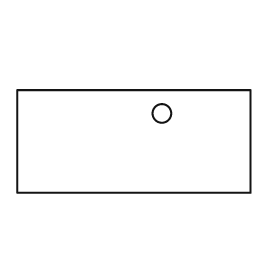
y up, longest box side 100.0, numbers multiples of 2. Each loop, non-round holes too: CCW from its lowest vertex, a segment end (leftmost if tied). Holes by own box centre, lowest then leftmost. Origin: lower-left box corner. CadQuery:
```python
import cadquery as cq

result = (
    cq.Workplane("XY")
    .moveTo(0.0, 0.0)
    .lineTo(100.0, 0.0)
    .lineTo(100.0, 44.0)
    .lineTo(0.0, 44.0)
    .close()
    .moveTo(62.0, 34.0)
    .circle(4.0)
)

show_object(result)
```